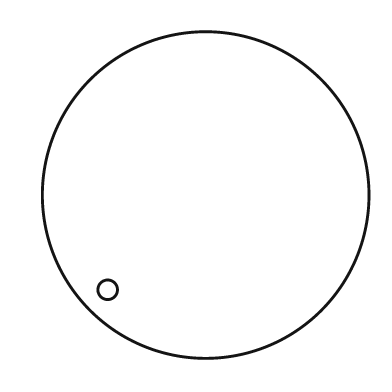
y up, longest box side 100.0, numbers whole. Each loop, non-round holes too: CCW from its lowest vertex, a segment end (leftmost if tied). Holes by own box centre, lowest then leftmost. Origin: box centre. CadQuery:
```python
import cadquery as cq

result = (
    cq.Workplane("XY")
    .moveTo(0.0, 0.0)
    .circle(50.0)
    .moveTo(-30.0, -29.0)
    .circle(3.0)
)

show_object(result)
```